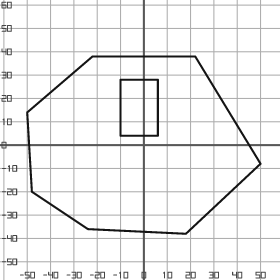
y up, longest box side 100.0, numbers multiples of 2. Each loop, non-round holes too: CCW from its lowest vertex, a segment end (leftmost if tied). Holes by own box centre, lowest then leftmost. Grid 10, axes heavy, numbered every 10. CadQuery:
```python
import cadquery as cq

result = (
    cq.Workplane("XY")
    .moveTo(18.0, -38.0)
    .lineTo(50.0, -8.0)
    .lineTo(22.0, 38.0)
    .lineTo(-22.0, 38.0)
    .lineTo(-50.0, 14.0)
    .lineTo(-48.0, -20.0)
    .lineTo(-24.0, -36.0)
    .close()
    .moveTo(-10.0, 4.0)
    .lineTo(6.0, 4.0)
    .lineTo(6.0, 28.0)
    .lineTo(-10.0, 28.0)
    .close()
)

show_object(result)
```